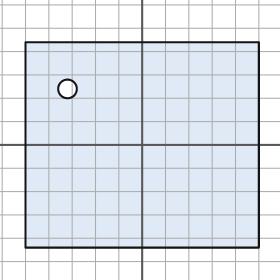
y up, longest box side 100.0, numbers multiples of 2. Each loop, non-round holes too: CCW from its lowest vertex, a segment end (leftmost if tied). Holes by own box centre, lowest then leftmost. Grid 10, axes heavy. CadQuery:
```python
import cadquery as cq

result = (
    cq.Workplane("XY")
    .moveTo(-50.0, -44.0)
    .lineTo(50.0, -44.0)
    .lineTo(50.0, 44.0)
    .lineTo(-50.0, 44.0)
    .close()
    .moveTo(-32.0, 24.0)
    .circle(4.0)
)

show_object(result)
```